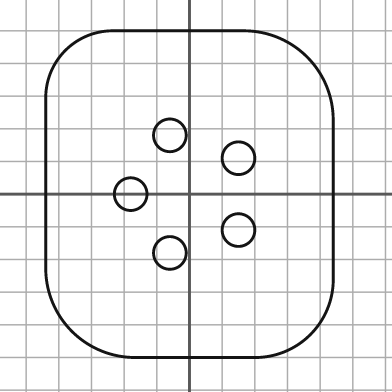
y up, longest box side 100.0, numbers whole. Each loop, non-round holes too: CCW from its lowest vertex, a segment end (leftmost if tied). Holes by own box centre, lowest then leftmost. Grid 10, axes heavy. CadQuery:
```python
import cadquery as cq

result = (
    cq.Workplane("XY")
    .moveTo(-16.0, -50.0)
    .lineTo(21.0, -50.0)
    .threePointArc((37.0, -43.0), (44.0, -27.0))
    .lineTo(44.0, 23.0)
    .threePointArc((36.0, 42.0), (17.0, 50.0))
    .lineTo(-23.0, 50.0)
    .threePointArc((-38.0, 44.0), (-44.0, 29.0))
    .lineTo(-44.0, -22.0)
    .threePointArc((-36.0, -42.0), (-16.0, -50.0))
    .close()
    .moveTo(-6.0, -18.0)
    .circle(5.0)
    .moveTo(15.0, -11.0)
    .circle(5.0)
    .moveTo(-18.0, 0.0)
    .circle(5.0)
    .moveTo(15.0, 11.0)
    .circle(5.0)
    .moveTo(-6.0, 18.0)
    .circle(5.0)
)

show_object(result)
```